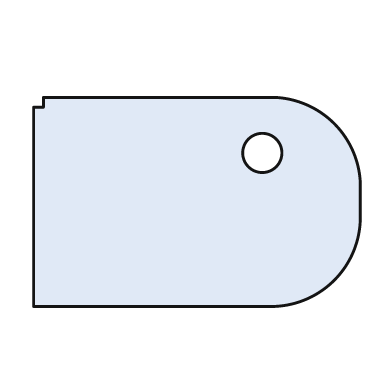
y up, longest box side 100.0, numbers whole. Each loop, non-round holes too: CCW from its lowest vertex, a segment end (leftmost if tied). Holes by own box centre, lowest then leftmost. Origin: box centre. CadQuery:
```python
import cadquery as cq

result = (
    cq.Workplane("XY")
    .moveTo(-50.0, -32.0)
    .lineTo(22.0, -32.0)
    .threePointArc((42.0, -24.0), (50.0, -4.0))
    .lineTo(50.0, 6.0)
    .threePointArc((42.0, 24.0), (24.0, 32.0))
    .lineTo(-47.0, 32.0)
    .lineTo(-47.0, 29.0)
    .lineTo(-50.0, 29.0)
    .close()
    .moveTo(20.0, 15.0)
    .circle(6.0)
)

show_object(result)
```